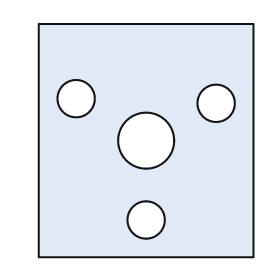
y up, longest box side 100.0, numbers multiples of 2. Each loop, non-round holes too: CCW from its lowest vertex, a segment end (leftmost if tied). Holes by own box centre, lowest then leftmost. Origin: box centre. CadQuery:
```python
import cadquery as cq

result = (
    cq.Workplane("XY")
    .moveTo(-46.0, -50.0)
    .lineTo(46.0, -50.0)
    .lineTo(46.0, 50.0)
    .lineTo(-46.0, 50.0)
    .close()
    .moveTo(0.0, -34.0)
    .circle(8.0)
    .moveTo(0.0, 0.0)
    .circle(12.0)
    .moveTo(30.0, 16.0)
    .circle(8.0)
    .moveTo(-30.0, 18.0)
    .circle(8.0)
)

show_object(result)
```